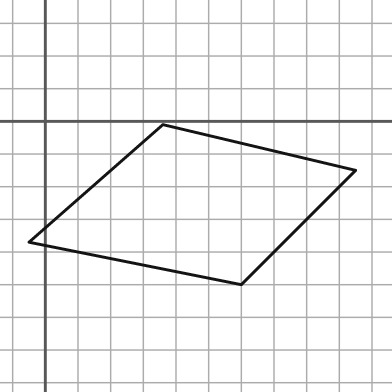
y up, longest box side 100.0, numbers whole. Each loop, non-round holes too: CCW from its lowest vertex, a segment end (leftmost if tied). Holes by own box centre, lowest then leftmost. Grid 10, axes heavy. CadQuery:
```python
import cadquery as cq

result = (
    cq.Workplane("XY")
    .moveTo(60.0, -50.0)
    .lineTo(95.0, -15.0)
    .lineTo(36.0, -1.0)
    .lineTo(-5.0, -37.0)
    .close()
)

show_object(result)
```